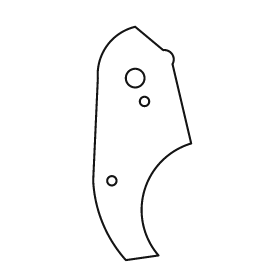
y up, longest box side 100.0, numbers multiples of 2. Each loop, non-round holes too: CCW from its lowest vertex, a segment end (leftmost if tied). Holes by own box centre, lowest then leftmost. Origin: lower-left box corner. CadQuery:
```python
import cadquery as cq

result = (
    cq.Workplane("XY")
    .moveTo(14.0, 0.0)
    .lineTo(28.0, 2.0)
    .threePointArc((22.0, 30.0), (42.0, 50.0))
    .lineTo(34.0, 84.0)
    .threePointArc((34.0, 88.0), (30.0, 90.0))
    .lineTo(18.0, 100.0)
    .threePointArc((6.0, 92.0), (2.0, 78.0))
    .lineTo(0.0, 34.0)
    .threePointArc((4.0, 16.0), (14.0, 0.0))
    .close()
    .moveTo(8.0, 34.0)
    .circle(2.0)
    .moveTo(22.0, 68.0)
    .circle(2.0)
    .moveTo(18.0, 78.0)
    .circle(4.0)
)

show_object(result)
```